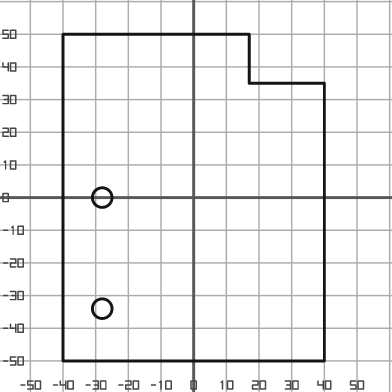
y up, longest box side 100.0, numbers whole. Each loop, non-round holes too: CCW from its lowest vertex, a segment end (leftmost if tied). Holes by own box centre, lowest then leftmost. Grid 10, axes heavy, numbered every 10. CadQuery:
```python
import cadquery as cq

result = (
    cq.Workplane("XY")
    .moveTo(-40.0, -50.0)
    .lineTo(40.0, -50.0)
    .lineTo(40.0, 35.0)
    .lineTo(17.0, 35.0)
    .lineTo(17.0, 50.0)
    .lineTo(-40.0, 50.0)
    .close()
    .moveTo(-28.0, -34.0)
    .circle(3.0)
    .moveTo(-28.0, 0.0)
    .circle(3.0)
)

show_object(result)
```